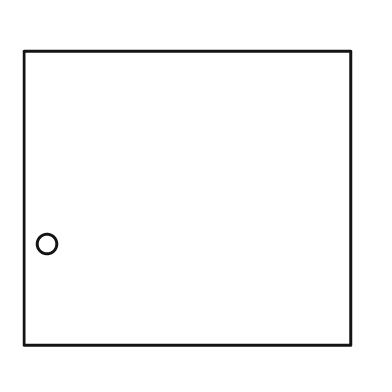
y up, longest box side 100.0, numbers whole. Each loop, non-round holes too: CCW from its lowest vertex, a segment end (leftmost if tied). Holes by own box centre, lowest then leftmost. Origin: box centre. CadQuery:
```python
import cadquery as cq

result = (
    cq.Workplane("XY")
    .moveTo(-50.0, -45.0)
    .lineTo(50.0, -45.0)
    .lineTo(50.0, 45.0)
    .lineTo(-50.0, 45.0)
    .close()
    .moveTo(-43.0, -14.0)
    .circle(3.0)
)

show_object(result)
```